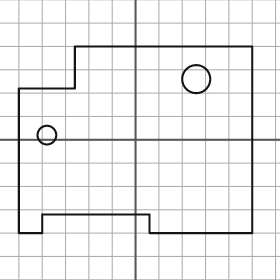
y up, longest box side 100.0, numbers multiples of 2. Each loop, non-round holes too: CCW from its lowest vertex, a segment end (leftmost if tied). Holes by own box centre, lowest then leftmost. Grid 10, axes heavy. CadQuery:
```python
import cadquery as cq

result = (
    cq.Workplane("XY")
    .moveTo(-50.0, -40.0)
    .lineTo(-40.0, -40.0)
    .lineTo(-40.0, -32.0)
    .lineTo(6.0, -32.0)
    .lineTo(6.0, -40.0)
    .lineTo(50.0, -40.0)
    .lineTo(50.0, 40.0)
    .lineTo(-26.0, 40.0)
    .lineTo(-26.0, 22.0)
    .lineTo(-50.0, 22.0)
    .close()
    .moveTo(-38.0, 2.0)
    .circle(4.0)
    .moveTo(26.0, 26.0)
    .circle(6.0)
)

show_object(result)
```